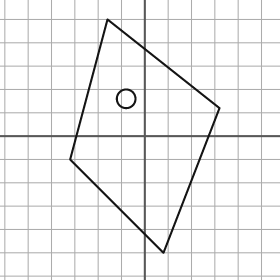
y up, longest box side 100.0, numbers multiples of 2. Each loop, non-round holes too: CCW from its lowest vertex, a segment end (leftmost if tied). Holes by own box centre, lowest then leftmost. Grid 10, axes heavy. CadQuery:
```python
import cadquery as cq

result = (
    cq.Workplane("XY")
    .moveTo(8.0, -50.0)
    .lineTo(32.0, 12.0)
    .lineTo(-16.0, 50.0)
    .lineTo(-32.0, -10.0)
    .close()
    .moveTo(-8.0, 16.0)
    .circle(4.0)
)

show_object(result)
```